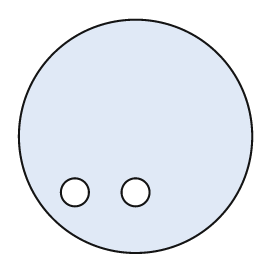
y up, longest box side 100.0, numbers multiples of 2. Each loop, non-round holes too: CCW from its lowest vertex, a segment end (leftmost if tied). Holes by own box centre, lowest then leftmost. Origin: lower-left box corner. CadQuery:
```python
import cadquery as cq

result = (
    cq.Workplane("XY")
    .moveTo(50.0, 50.0)
    .circle(50.0)
    .moveTo(24.0, 26.0)
    .circle(6.0)
    .moveTo(50.0, 26.0)
    .circle(6.0)
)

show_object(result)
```